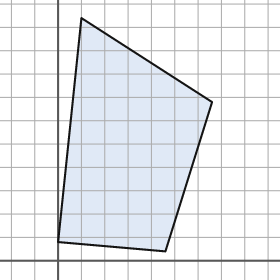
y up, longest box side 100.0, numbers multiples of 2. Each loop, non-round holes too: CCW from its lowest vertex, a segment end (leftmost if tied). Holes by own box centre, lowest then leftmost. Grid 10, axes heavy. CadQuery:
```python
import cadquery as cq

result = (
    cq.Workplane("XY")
    .moveTo(46.0, 4.0)
    .lineTo(66.0, 68.0)
    .lineTo(10.0, 104.0)
    .lineTo(0.0, 8.0)
    .close()
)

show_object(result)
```